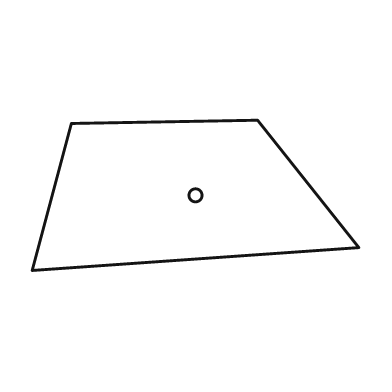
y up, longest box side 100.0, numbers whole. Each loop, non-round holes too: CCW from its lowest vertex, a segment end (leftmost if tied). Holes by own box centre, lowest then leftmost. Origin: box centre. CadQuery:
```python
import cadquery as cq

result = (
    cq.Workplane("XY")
    .moveTo(-50.0, -23.0)
    .lineTo(50.0, -16.0)
    .lineTo(19.0, 23.0)
    .lineTo(-38.0, 22.0)
    .close()
    .moveTo(0.0, 0.0)
    .circle(2.0)
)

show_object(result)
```